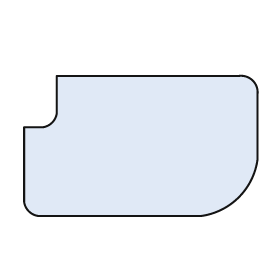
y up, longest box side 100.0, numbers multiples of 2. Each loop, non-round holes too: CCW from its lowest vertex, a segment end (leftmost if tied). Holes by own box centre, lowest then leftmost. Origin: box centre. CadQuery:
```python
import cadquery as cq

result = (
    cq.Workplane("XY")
    .moveTo(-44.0, -30.0)
    .lineTo(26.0, -30.0)
    .threePointArc((42.0, -22.0), (50.0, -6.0))
    .lineTo(50.0, 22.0)
    .threePointArc((48.0, 28.0), (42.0, 30.0))
    .lineTo(-36.0, 30.0)
    .lineTo(-36.0, 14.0)
    .threePointArc((-38.0, 10.0), (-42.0, 8.0))
    .lineTo(-50.0, 8.0)
    .lineTo(-50.0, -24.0)
    .threePointArc((-48.0, -28.0), (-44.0, -30.0))
    .close()
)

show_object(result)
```